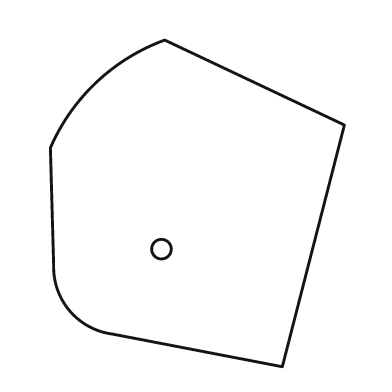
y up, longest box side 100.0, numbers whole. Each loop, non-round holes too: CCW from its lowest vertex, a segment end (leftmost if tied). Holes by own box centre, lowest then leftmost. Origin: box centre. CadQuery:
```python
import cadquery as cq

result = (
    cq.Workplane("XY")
    .moveTo(26.0, -50.0)
    .lineTo(45.0, 24.0)
    .lineTo(-10.0, 50.0)
    .threePointArc((-31.0, 37.0), (-45.0, 17.0))
    .lineTo(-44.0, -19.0)
    .threePointArc((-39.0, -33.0), (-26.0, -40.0))
    .close()
    .moveTo(-11.0, -14.0)
    .circle(3.0)
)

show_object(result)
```